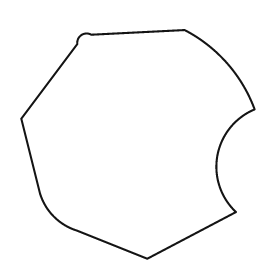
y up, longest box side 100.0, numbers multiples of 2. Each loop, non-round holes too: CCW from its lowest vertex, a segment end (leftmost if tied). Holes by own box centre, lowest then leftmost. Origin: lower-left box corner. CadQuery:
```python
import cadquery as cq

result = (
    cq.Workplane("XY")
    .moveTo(54.0, 0.0)
    .lineTo(92.0, 20.0)
    .threePointArc((84.0, 44.0), (100.0, 64.0))
    .threePointArc((88.0, 84.0), (70.0, 98.0))
    .lineTo(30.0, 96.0)
    .threePointArc((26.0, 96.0), (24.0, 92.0))
    .lineTo(0.0, 60.0)
    .lineTo(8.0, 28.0)
    .threePointArc((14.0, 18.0), (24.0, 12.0))
    .close()
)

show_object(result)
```